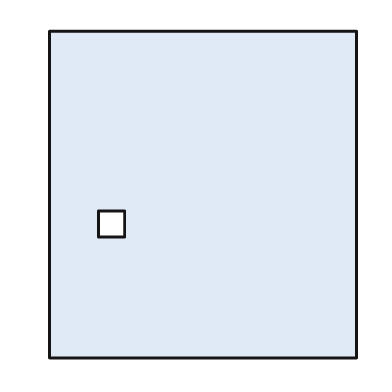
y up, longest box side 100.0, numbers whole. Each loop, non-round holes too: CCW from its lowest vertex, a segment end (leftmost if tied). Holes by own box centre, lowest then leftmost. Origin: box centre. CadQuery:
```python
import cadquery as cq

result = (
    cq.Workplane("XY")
    .moveTo(-47.0, -50.0)
    .lineTo(47.0, -50.0)
    .lineTo(47.0, 50.0)
    .lineTo(-47.0, 50.0)
    .close()
    .moveTo(-32.0, -13.0)
    .lineTo(-24.0, -13.0)
    .lineTo(-24.0, -5.0)
    .lineTo(-32.0, -5.0)
    .close()
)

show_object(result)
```